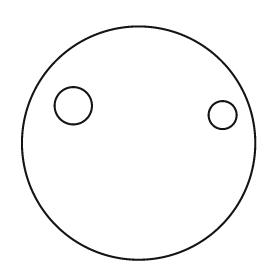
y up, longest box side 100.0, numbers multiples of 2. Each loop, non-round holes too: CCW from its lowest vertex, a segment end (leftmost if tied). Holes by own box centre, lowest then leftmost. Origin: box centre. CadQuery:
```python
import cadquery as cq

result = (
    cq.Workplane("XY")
    .moveTo(0.0, 0.0)
    .circle(50.0)
    .moveTo(36.0, 12.0)
    .circle(6.0)
    .moveTo(-28.0, 16.0)
    .circle(8.0)
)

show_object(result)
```